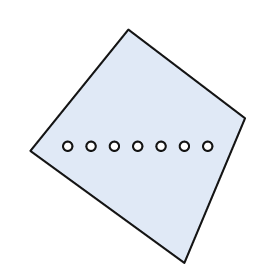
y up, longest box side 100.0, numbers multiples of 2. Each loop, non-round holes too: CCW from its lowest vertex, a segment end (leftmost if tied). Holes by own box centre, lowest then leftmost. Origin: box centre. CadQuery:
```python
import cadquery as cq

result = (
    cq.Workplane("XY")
    .moveTo(20.0, -50.0)
    .lineTo(46.0, 12.0)
    .lineTo(-4.0, 50.0)
    .lineTo(-46.0, -2.0)
    .close()
    .moveTo(-30.0, 0.0)
    .circle(2.0)
    .moveTo(-20.0, 0.0)
    .circle(2.0)
    .moveTo(-10.0, 0.0)
    .circle(2.0)
    .moveTo(0.0, 0.0)
    .circle(2.0)
    .moveTo(10.0, 0.0)
    .circle(2.0)
    .moveTo(20.0, 0.0)
    .circle(2.0)
    .moveTo(30.0, 0.0)
    .circle(2.0)
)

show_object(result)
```